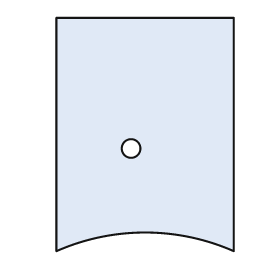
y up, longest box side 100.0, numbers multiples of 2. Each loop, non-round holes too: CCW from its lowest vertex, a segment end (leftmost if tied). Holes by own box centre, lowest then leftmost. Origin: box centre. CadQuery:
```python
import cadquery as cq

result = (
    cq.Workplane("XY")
    .moveTo(-38.0, -50.0)
    .threePointArc((0.0, -42.0), (38.0, -50.0))
    .lineTo(38.0, 50.0)
    .lineTo(-38.0, 50.0)
    .close()
    .moveTo(-6.0, -6.0)
    .circle(4.0)
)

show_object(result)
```